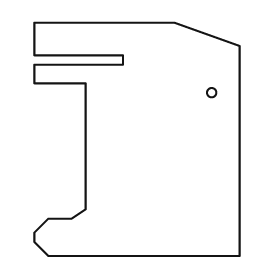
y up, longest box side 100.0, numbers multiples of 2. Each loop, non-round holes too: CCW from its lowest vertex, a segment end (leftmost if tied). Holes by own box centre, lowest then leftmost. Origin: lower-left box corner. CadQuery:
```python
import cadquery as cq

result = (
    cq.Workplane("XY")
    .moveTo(6.0, 0.0)
    .lineTo(88.0, 0.0)
    .lineTo(88.0, 90.0)
    .lineTo(60.0, 100.0)
    .lineTo(0.0, 100.0)
    .lineTo(0.0, 86.0)
    .lineTo(38.0, 86.0)
    .lineTo(38.0, 82.0)
    .lineTo(0.0, 82.0)
    .lineTo(0.0, 74.0)
    .lineTo(22.0, 74.0)
    .lineTo(22.0, 20.0)
    .lineTo(16.0, 16.0)
    .lineTo(6.0, 16.0)
    .lineTo(0.0, 10.0)
    .lineTo(0.0, 6.0)
    .close()
    .moveTo(76.0, 70.0)
    .circle(2.0)
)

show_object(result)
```